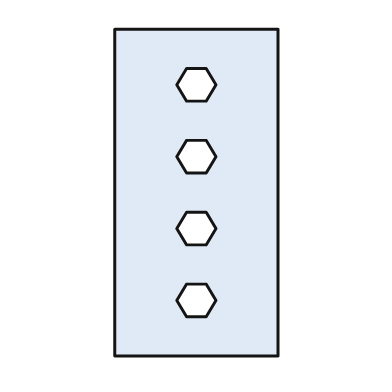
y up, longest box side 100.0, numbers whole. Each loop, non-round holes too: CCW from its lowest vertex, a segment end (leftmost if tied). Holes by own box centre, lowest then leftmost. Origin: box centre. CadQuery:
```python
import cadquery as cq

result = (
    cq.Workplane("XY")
    .moveTo(-25.0, -50.0)
    .lineTo(25.0, -50.0)
    .lineTo(25.0, 50.0)
    .lineTo(-25.0, 50.0)
    .close()
    .moveTo(-3.0, -38.0)
    .lineTo(3.0, -38.0)
    .lineTo(6.0, -33.0)
    .lineTo(3.0, -28.0)
    .lineTo(-3.0, -28.0)
    .lineTo(-6.0, -33.0)
    .close()
    .moveTo(-3.0, -16.0)
    .lineTo(3.0, -16.0)
    .lineTo(6.0, -11.0)
    .lineTo(3.0, -6.0)
    .lineTo(-3.0, -6.0)
    .lineTo(-6.0, -11.0)
    .close()
    .moveTo(-3.0, 6.0)
    .lineTo(3.0, 6.0)
    .lineTo(6.0, 11.0)
    .lineTo(3.0, 16.0)
    .lineTo(-3.0, 16.0)
    .lineTo(-6.0, 11.0)
    .close()
    .moveTo(-3.0, 28.0)
    .lineTo(3.0, 28.0)
    .lineTo(6.0, 33.0)
    .lineTo(3.0, 38.0)
    .lineTo(-3.0, 38.0)
    .lineTo(-6.0, 33.0)
    .close()
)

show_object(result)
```